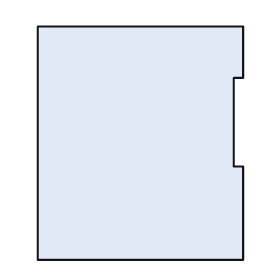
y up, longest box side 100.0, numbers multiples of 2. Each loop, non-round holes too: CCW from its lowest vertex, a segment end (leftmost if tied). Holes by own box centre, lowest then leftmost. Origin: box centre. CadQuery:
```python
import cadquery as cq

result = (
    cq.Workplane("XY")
    .moveTo(-44.0, -50.0)
    .lineTo(44.0, -50.0)
    .lineTo(44.0, -10.0)
    .lineTo(40.0, -10.0)
    .lineTo(40.0, 28.0)
    .lineTo(44.0, 28.0)
    .lineTo(44.0, 50.0)
    .lineTo(-44.0, 50.0)
    .close()
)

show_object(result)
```